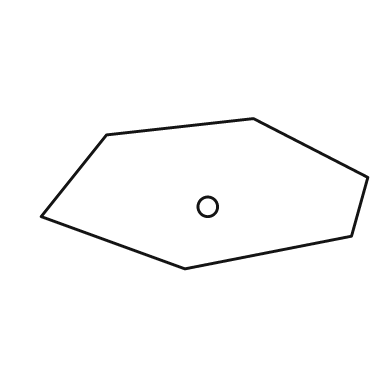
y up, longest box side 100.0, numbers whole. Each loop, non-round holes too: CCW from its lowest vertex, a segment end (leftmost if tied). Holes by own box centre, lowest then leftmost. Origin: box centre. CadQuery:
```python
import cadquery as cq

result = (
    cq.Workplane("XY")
    .moveTo(-6.0, -23.0)
    .lineTo(45.0, -13.0)
    .lineTo(50.0, 5.0)
    .lineTo(15.0, 23.0)
    .lineTo(-30.0, 18.0)
    .lineTo(-50.0, -7.0)
    .close()
    .moveTo(1.0, -4.0)
    .circle(3.0)
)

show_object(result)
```